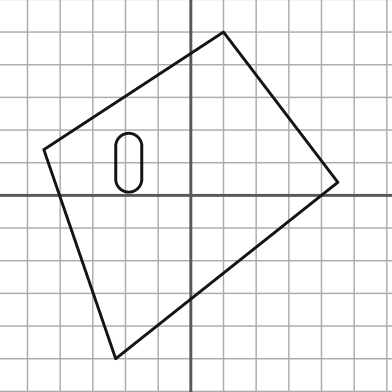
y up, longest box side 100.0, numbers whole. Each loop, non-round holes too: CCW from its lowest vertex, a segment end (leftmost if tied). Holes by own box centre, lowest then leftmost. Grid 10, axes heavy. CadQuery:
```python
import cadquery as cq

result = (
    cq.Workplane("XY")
    .moveTo(-23.0, -50.0)
    .lineTo(45.0, 4.0)
    .lineTo(10.0, 50.0)
    .lineTo(-45.0, 14.0)
    .close()
    .moveTo(-23.0, 5.0)
    .threePointArc((-19.0, 1.0), (-15.0, 5.0))
    .lineTo(-15.0, 15.0)
    .threePointArc((-19.0, 19.0), (-23.0, 15.0))
    .close()
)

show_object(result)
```